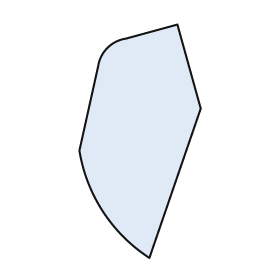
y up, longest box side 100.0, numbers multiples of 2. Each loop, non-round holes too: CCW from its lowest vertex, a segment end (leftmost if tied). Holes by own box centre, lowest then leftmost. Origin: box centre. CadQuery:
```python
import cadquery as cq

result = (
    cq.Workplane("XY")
    .moveTo(4.0, -50.0)
    .lineTo(26.0, 14.0)
    .lineTo(16.0, 50.0)
    .lineTo(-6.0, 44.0)
    .threePointArc((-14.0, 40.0), (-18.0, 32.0))
    .lineTo(-26.0, -4.0)
    .threePointArc((-16.0, -30.0), (4.0, -50.0))
    .close()
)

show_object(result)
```